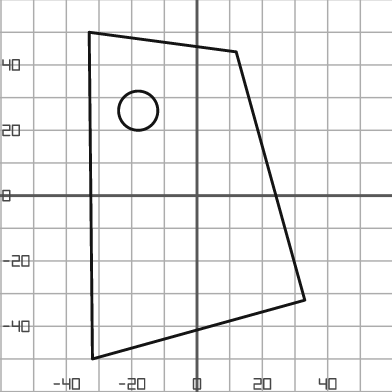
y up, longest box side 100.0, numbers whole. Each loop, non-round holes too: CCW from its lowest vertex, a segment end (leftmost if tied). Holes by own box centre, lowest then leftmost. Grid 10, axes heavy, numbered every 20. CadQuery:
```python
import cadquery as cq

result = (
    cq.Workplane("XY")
    .moveTo(-32.0, -50.0)
    .lineTo(33.0, -32.0)
    .lineTo(12.0, 44.0)
    .lineTo(-33.0, 50.0)
    .close()
    .moveTo(-18.0, 26.0)
    .circle(6.0)
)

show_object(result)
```